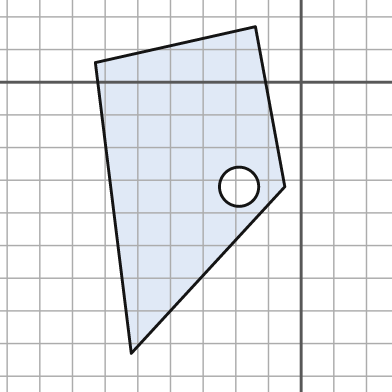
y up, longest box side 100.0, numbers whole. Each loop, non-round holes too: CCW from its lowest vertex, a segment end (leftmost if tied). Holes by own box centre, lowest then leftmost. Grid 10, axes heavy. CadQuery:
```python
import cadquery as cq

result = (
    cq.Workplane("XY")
    .moveTo(-52.0, -83.0)
    .lineTo(-5.0, -32.0)
    .lineTo(-14.0, 17.0)
    .lineTo(-63.0, 6.0)
    .close()
    .moveTo(-19.0, -32.0)
    .circle(6.0)
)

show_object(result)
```